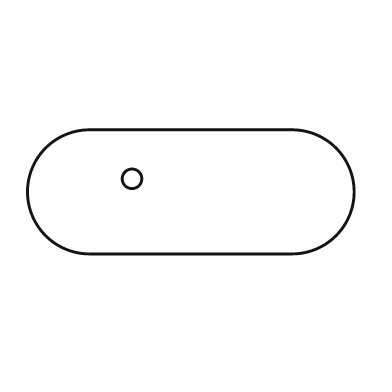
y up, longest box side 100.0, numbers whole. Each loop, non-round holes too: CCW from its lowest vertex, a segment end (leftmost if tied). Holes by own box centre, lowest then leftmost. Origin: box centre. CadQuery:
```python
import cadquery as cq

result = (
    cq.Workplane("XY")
    .moveTo(-31.0, -19.0)
    .lineTo(31.0, -19.0)
    .threePointArc((50.0, 0.0), (31.0, 19.0))
    .lineTo(-31.0, 19.0)
    .threePointArc((-50.0, 0.0), (-31.0, -19.0))
    .close()
    .moveTo(-18.0, 4.0)
    .circle(3.0)
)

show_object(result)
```